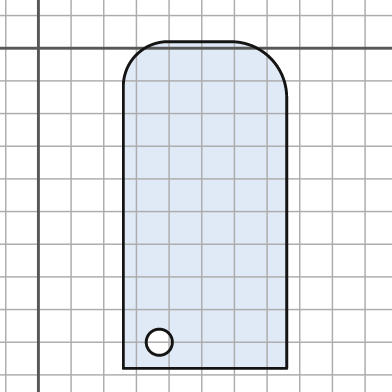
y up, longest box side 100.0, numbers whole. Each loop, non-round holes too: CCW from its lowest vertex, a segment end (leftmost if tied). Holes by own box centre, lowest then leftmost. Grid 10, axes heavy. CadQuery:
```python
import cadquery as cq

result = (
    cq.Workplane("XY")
    .moveTo(26.0, -98.0)
    .lineTo(76.0, -98.0)
    .lineTo(76.0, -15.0)
    .threePointArc((71.0, -3.0), (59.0, 2.0))
    .lineTo(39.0, 2.0)
    .threePointArc((30.0, -2.0), (26.0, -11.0))
    .close()
    .moveTo(37.0, -90.0)
    .circle(4.0)
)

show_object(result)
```